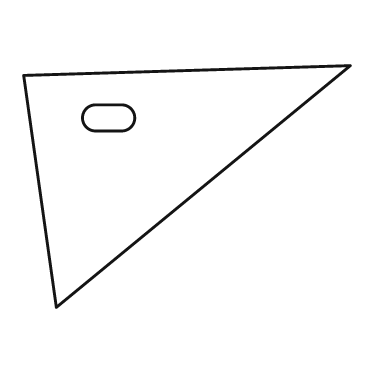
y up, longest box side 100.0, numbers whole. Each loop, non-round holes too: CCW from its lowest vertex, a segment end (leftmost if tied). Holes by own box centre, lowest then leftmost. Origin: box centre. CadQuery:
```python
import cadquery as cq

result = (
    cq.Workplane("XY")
    .moveTo(-40.0, -37.0)
    .lineTo(50.0, 37.0)
    .lineTo(-50.0, 34.0)
    .close()
    .moveTo(-28.0, 17.0)
    .lineTo(-20.0, 17.0)
    .threePointArc((-16.0, 21.0), (-20.0, 25.0))
    .lineTo(-28.0, 25.0)
    .threePointArc((-32.0, 21.0), (-28.0, 17.0))
    .close()
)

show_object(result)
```